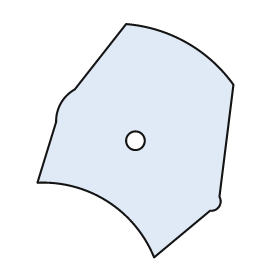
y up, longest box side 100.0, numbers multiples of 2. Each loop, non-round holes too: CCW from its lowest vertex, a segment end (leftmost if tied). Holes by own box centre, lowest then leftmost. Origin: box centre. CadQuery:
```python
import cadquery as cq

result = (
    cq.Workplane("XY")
    .moveTo(8.0, -50.0)
    .lineTo(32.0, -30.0)
    .threePointArc((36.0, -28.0), (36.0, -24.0))
    .lineTo(42.0, 24.0)
    .threePointArc((22.0, 42.0), (-4.0, 50.0))
    .lineTo(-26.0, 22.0)
    .threePointArc((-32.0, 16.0), (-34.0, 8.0))
    .lineTo(-42.0, -18.0)
    .threePointArc((-12.0, -26.0), (8.0, -50.0))
    .close()
    .moveTo(0.0, 0.0)
    .circle(4.0)
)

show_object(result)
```